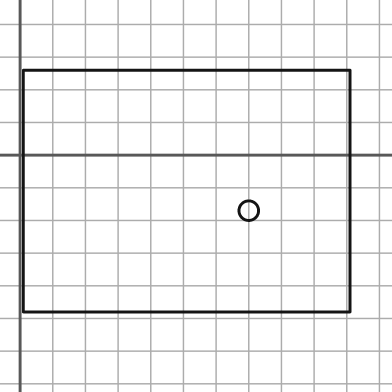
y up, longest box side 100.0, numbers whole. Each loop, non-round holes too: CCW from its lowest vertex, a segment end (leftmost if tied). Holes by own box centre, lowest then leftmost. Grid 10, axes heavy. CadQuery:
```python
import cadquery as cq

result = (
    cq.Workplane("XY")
    .moveTo(1.0, -48.0)
    .lineTo(101.0, -48.0)
    .lineTo(101.0, 26.0)
    .lineTo(1.0, 26.0)
    .close()
    .moveTo(70.0, -17.0)
    .circle(3.0)
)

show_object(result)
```